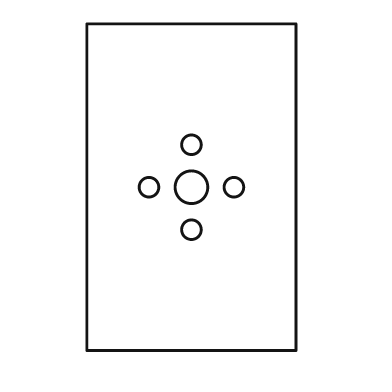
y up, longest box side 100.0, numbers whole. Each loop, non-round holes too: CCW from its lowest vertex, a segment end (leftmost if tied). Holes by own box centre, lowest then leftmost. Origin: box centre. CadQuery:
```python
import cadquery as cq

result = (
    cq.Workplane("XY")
    .moveTo(-32.0, -50.0)
    .lineTo(32.0, -50.0)
    .lineTo(32.0, 50.0)
    .lineTo(-32.0, 50.0)
    .close()
    .moveTo(0.0, -13.0)
    .circle(3.0)
    .moveTo(-13.0, 0.0)
    .circle(3.0)
    .moveTo(0.0, 0.0)
    .circle(5.0)
    .moveTo(13.0, 0.0)
    .circle(3.0)
    .moveTo(0.0, 13.0)
    .circle(3.0)
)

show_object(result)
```